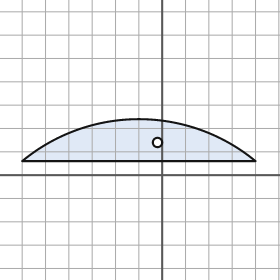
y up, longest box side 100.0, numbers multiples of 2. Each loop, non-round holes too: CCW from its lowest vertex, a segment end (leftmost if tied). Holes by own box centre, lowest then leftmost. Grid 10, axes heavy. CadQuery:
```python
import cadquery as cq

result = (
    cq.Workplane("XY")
    .moveTo(-60.0, 6.0)
    .lineTo(40.0, 6.0)
    .threePointArc((-10.0, 24.0), (-60.0, 6.0))
    .close()
    .moveTo(-2.0, 14.0)
    .circle(2.0)
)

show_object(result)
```